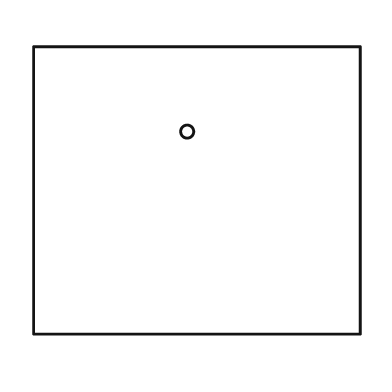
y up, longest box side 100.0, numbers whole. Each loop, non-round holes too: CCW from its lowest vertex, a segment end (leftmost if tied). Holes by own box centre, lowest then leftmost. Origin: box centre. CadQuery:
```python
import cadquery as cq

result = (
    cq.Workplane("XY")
    .moveTo(-50.0, -44.0)
    .lineTo(50.0, -44.0)
    .lineTo(50.0, 44.0)
    .lineTo(-50.0, 44.0)
    .close()
    .moveTo(-3.0, 18.0)
    .circle(2.0)
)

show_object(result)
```